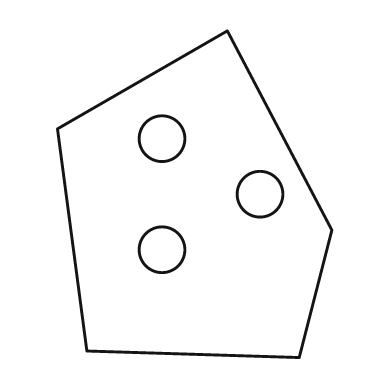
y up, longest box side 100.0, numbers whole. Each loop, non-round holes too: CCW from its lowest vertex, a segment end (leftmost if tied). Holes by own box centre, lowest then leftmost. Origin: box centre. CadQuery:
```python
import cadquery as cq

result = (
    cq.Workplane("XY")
    .moveTo(32.0, -50.0)
    .lineTo(42.0, -11.0)
    .lineTo(10.0, 50.0)
    .lineTo(-42.0, 20.0)
    .lineTo(-33.0, -48.0)
    .close()
    .moveTo(-10.0, -17.0)
    .circle(7.0)
    .moveTo(20.0, 0.0)
    .circle(7.0)
    .moveTo(-10.0, 17.0)
    .circle(7.0)
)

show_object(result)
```